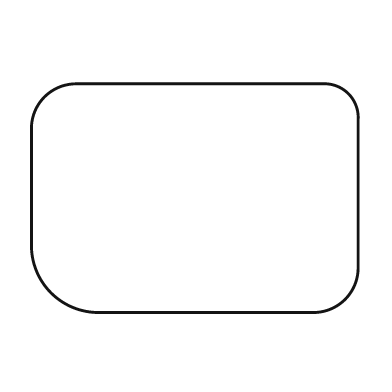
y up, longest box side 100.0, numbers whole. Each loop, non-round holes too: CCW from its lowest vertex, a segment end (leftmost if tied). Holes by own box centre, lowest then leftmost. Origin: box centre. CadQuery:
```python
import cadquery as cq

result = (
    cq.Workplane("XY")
    .moveTo(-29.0, -35.0)
    .lineTo(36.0, -35.0)
    .threePointArc((46.0, -31.0), (50.0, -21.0))
    .lineTo(50.0, 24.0)
    .threePointArc((47.0, 32.0), (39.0, 35.0))
    .lineTo(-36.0, 35.0)
    .threePointArc((-46.0, 31.0), (-50.0, 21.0))
    .lineTo(-50.0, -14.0)
    .threePointArc((-44.0, -29.0), (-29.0, -35.0))
    .close()
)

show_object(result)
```